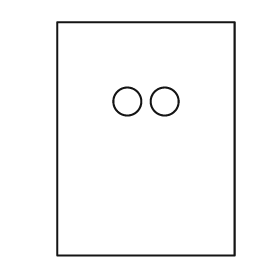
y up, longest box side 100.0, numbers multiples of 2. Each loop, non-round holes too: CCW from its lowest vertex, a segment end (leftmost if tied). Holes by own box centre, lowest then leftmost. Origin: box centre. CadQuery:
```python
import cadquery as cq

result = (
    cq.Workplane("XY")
    .moveTo(-38.0, -50.0)
    .lineTo(38.0, -50.0)
    .lineTo(38.0, 50.0)
    .lineTo(-38.0, 50.0)
    .close()
    .moveTo(-8.0, 16.0)
    .circle(6.0)
    .moveTo(8.0, 16.0)
    .circle(6.0)
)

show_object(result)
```